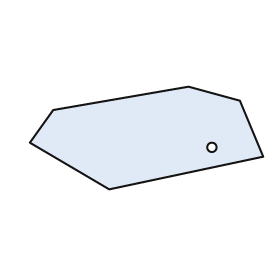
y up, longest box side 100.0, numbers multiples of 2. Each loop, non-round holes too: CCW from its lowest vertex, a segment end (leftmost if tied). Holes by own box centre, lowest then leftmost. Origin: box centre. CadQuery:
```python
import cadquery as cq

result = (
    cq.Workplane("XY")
    .moveTo(-16.0, -22.0)
    .lineTo(50.0, -8.0)
    .lineTo(40.0, 16.0)
    .lineTo(18.0, 22.0)
    .lineTo(-40.0, 12.0)
    .lineTo(-50.0, -2.0)
    .close()
    .moveTo(28.0, -4.0)
    .circle(2.0)
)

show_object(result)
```